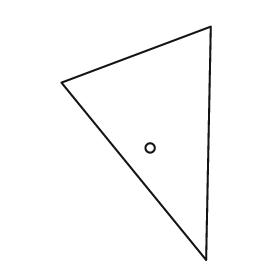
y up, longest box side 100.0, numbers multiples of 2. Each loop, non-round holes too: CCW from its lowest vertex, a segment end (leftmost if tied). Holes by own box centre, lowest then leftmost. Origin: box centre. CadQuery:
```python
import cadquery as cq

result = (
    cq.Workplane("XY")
    .moveTo(30.0, -50.0)
    .lineTo(32.0, 50.0)
    .lineTo(-32.0, 26.0)
    .close()
    .moveTo(6.0, -2.0)
    .circle(2.0)
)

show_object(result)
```